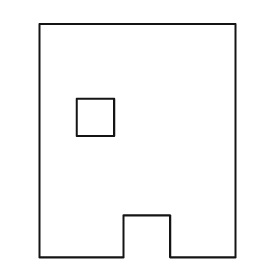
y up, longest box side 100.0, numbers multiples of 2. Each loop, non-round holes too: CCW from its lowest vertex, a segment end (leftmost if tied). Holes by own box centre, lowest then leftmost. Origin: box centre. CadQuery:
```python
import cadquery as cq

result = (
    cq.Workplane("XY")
    .moveTo(-42.0, -50.0)
    .lineTo(-6.0, -50.0)
    .lineTo(-6.0, -32.0)
    .lineTo(14.0, -32.0)
    .lineTo(14.0, -50.0)
    .lineTo(42.0, -50.0)
    .lineTo(42.0, 50.0)
    .lineTo(-42.0, 50.0)
    .close()
    .moveTo(-26.0, 2.0)
    .lineTo(-10.0, 2.0)
    .lineTo(-10.0, 18.0)
    .lineTo(-26.0, 18.0)
    .close()
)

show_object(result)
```